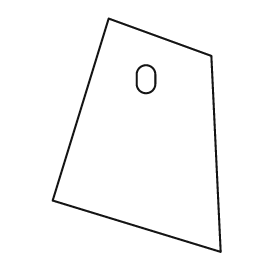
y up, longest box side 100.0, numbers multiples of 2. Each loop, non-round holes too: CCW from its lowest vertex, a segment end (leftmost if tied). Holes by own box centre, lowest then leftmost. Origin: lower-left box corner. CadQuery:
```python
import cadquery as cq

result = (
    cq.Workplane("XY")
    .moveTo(72.0, 0.0)
    .lineTo(68.0, 84.0)
    .lineTo(24.0, 100.0)
    .lineTo(0.0, 22.0)
    .close()
    .moveTo(36.0, 72.0)
    .threePointArc((40.0, 68.0), (44.0, 72.0))
    .lineTo(44.0, 76.0)
    .threePointArc((40.0, 80.0), (36.0, 76.0))
    .close()
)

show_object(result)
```